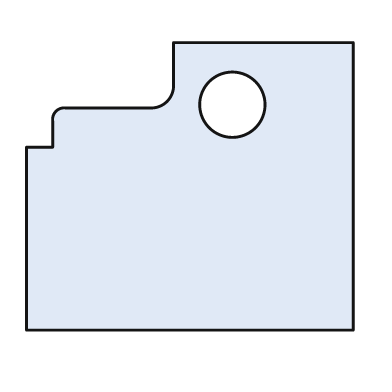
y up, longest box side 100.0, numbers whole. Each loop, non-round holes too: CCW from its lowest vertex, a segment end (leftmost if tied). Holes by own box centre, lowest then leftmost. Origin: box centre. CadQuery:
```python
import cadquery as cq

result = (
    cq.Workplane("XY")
    .moveTo(-50.0, -44.0)
    .lineTo(50.0, -44.0)
    .lineTo(50.0, 44.0)
    .lineTo(-5.0, 44.0)
    .lineTo(-5.0, 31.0)
    .threePointArc((-7.0, 26.0), (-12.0, 24.0))
    .lineTo(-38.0, 24.0)
    .threePointArc((-41.0, 23.0), (-42.0, 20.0))
    .lineTo(-42.0, 12.0)
    .lineTo(-50.0, 12.0)
    .close()
    .moveTo(13.0, 25.0)
    .circle(10.0)
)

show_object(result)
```